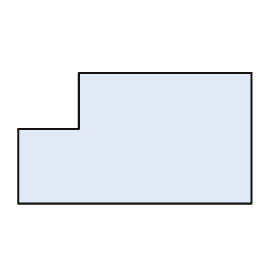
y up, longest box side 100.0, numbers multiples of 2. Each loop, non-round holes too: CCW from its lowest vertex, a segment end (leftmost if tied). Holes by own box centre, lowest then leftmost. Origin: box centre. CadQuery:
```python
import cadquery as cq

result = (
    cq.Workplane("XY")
    .moveTo(-50.0, -28.0)
    .lineTo(50.0, -28.0)
    .lineTo(50.0, 28.0)
    .lineTo(-24.0, 28.0)
    .lineTo(-24.0, 4.0)
    .lineTo(-50.0, 4.0)
    .close()
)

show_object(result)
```